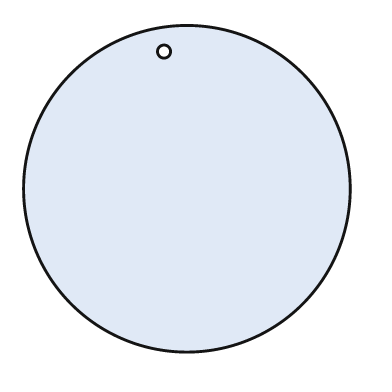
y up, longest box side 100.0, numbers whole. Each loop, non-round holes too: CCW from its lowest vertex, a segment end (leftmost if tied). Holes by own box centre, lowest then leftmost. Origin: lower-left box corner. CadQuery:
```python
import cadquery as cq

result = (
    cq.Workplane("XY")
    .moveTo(50.0, 50.0)
    .circle(50.0)
    .moveTo(43.0, 92.0)
    .circle(2.0)
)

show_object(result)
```